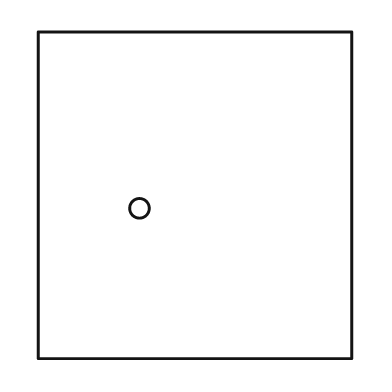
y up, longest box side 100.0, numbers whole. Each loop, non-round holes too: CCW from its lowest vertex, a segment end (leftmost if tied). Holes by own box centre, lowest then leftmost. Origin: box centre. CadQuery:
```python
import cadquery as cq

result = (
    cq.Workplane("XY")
    .moveTo(-48.0, -50.0)
    .lineTo(48.0, -50.0)
    .lineTo(48.0, 50.0)
    .lineTo(-48.0, 50.0)
    .close()
    .moveTo(-17.0, -4.0)
    .circle(3.0)
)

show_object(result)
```